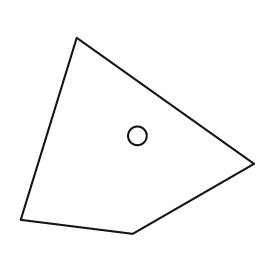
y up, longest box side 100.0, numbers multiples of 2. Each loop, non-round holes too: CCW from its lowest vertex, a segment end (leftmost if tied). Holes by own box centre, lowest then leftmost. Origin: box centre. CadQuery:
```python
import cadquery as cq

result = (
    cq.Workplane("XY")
    .moveTo(-2.0, -42.0)
    .lineTo(50.0, -12.0)
    .lineTo(-26.0, 42.0)
    .lineTo(-50.0, -36.0)
    .close()
    .moveTo(0.0, 0.0)
    .circle(4.0)
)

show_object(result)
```